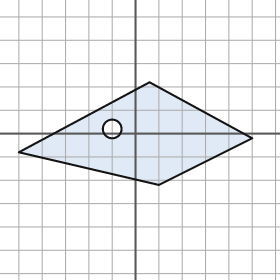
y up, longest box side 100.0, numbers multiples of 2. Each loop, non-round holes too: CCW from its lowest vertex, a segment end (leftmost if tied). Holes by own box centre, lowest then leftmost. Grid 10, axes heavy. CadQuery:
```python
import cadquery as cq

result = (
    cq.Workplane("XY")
    .moveTo(10.0, -22.0)
    .lineTo(50.0, -2.0)
    .lineTo(6.0, 22.0)
    .lineTo(-50.0, -8.0)
    .close()
    .moveTo(-10.0, 2.0)
    .circle(4.0)
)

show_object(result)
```